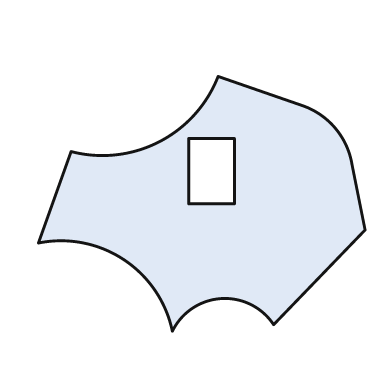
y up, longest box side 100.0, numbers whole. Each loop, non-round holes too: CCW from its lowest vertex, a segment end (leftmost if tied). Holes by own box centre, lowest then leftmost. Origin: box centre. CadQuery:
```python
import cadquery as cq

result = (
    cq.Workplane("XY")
    .moveTo(-9.0, -39.0)
    .threePointArc((6.0, -29.0), (22.0, -37.0))
    .lineTo(50.0, -8.0)
    .lineTo(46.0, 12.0)
    .threePointArc((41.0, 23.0), (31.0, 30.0))
    .lineTo(5.0, 39.0)
    .threePointArc((-13.0, 19.0), (-40.0, 16.0))
    .lineTo(-50.0, -12.0)
    .threePointArc((-24.0, -17.0), (-9.0, -39.0))
    .close()
    .moveTo(-4.0, 0.0)
    .lineTo(10.0, 0.0)
    .lineTo(10.0, 20.0)
    .lineTo(-4.0, 20.0)
    .close()
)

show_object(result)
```